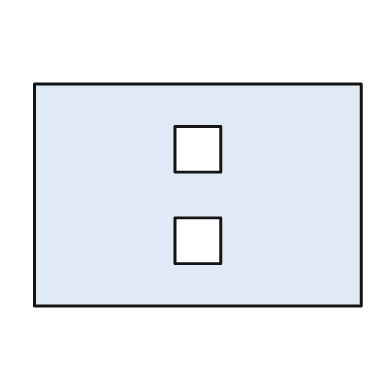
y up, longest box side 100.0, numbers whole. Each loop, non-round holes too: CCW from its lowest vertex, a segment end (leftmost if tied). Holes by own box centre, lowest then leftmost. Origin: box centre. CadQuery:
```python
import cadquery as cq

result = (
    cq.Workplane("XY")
    .moveTo(-50.0, -34.0)
    .lineTo(50.0, -34.0)
    .lineTo(50.0, 34.0)
    .lineTo(-50.0, 34.0)
    .close()
    .moveTo(-7.0, -21.0)
    .lineTo(7.0, -21.0)
    .lineTo(7.0, -7.0)
    .lineTo(-7.0, -7.0)
    .close()
    .moveTo(-7.0, 7.0)
    .lineTo(7.0, 7.0)
    .lineTo(7.0, 21.0)
    .lineTo(-7.0, 21.0)
    .close()
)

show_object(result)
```